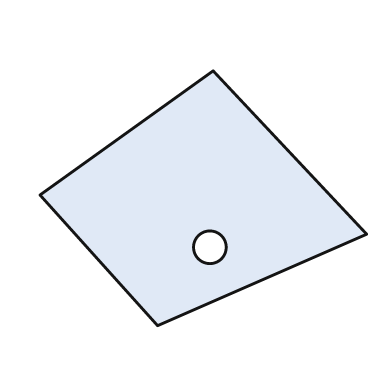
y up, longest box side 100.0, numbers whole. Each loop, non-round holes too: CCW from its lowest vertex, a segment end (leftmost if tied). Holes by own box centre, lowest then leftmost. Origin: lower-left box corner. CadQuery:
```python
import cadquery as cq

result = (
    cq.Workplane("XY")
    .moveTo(36.0, 0.0)
    .lineTo(100.0, 28.0)
    .lineTo(53.0, 78.0)
    .lineTo(0.0, 40.0)
    .close()
    .moveTo(52.0, 24.0)
    .circle(5.0)
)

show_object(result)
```